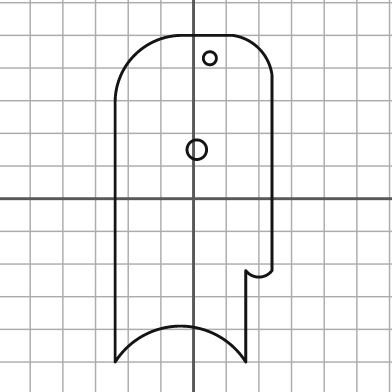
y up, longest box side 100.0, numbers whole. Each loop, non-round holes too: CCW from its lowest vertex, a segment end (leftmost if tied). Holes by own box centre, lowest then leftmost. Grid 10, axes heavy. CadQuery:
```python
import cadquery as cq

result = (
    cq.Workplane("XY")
    .moveTo(-24.0, -50.0)
    .threePointArc((-4.0, -39.0), (16.0, -50.0))
    .lineTo(16.0, -22.0)
    .threePointArc((20.0, -24.0), (24.0, -22.0))
    .lineTo(24.0, 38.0)
    .threePointArc((20.0, 46.0), (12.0, 50.0))
    .lineTo(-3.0, 50.0)
    .threePointArc((-18.0, 44.0), (-24.0, 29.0))
    .close()
    .moveTo(1.0, 15.0)
    .circle(3.0)
    .moveTo(5.0, 43.0)
    .circle(2.0)
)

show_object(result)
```